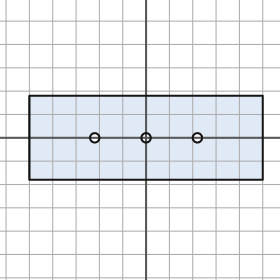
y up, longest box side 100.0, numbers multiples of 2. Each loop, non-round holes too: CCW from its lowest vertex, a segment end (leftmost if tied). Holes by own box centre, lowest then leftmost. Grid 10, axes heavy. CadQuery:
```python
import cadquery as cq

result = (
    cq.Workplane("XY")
    .moveTo(-50.0, -18.0)
    .lineTo(50.0, -18.0)
    .lineTo(50.0, 18.0)
    .lineTo(-50.0, 18.0)
    .close()
    .moveTo(-22.0, 0.0)
    .circle(2.0)
    .moveTo(0.0, 0.0)
    .circle(2.0)
    .moveTo(22.0, 0.0)
    .circle(2.0)
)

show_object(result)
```